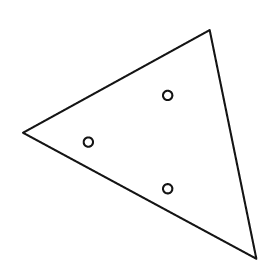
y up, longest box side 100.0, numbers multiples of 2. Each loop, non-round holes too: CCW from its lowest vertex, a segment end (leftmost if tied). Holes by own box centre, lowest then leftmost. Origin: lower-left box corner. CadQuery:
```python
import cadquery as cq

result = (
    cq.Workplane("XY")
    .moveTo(100.0, 0.0)
    .lineTo(80.0, 98.0)
    .lineTo(0.0, 54.0)
    .close()
    .moveTo(62.0, 30.0)
    .circle(2.0)
    .moveTo(28.0, 50.0)
    .circle(2.0)
    .moveTo(62.0, 70.0)
    .circle(2.0)
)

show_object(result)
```